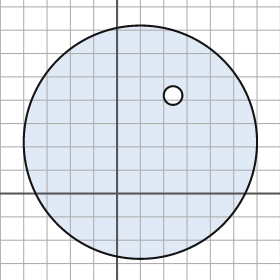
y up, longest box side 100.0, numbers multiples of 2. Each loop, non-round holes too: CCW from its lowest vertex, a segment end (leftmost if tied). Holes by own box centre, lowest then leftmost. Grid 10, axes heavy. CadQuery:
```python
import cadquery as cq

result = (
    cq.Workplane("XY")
    .moveTo(10.0, 22.0)
    .circle(50.0)
    .moveTo(24.0, 42.0)
    .circle(4.0)
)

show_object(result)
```